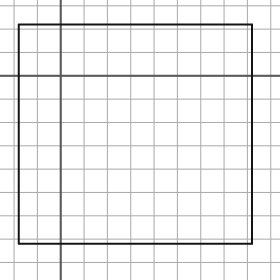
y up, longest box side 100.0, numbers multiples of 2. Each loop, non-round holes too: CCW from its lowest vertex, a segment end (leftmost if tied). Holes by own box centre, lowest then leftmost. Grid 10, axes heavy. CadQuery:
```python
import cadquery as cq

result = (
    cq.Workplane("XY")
    .moveTo(-18.0, -72.0)
    .lineTo(82.0, -72.0)
    .lineTo(82.0, 22.0)
    .lineTo(-18.0, 22.0)
    .close()
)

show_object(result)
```